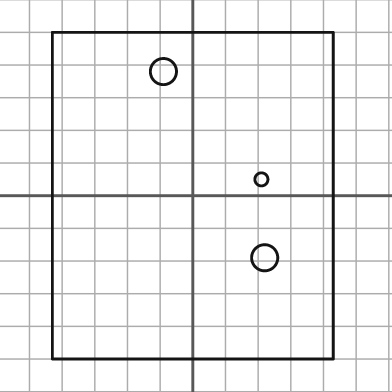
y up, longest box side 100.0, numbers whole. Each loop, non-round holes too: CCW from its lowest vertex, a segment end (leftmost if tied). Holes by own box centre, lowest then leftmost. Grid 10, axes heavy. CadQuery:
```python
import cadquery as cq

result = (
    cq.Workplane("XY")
    .moveTo(-43.0, -50.0)
    .lineTo(43.0, -50.0)
    .lineTo(43.0, 50.0)
    .lineTo(-43.0, 50.0)
    .close()
    .moveTo(22.0, -19.0)
    .circle(4.0)
    .moveTo(21.0, 5.0)
    .circle(2.0)
    .moveTo(-9.0, 38.0)
    .circle(4.0)
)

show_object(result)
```